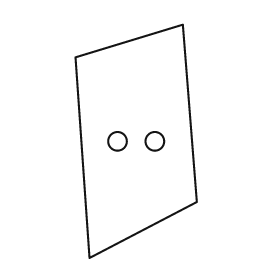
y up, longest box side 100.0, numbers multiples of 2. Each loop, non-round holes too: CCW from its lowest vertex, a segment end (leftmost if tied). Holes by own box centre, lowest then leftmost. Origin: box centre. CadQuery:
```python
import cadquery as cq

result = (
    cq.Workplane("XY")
    .moveTo(-20.0, -50.0)
    .lineTo(26.0, -26.0)
    .lineTo(20.0, 50.0)
    .lineTo(-26.0, 36.0)
    .close()
    .moveTo(-8.0, 0.0)
    .circle(4.0)
    .moveTo(8.0, 0.0)
    .circle(4.0)
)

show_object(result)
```